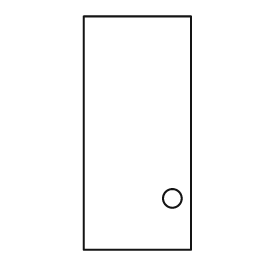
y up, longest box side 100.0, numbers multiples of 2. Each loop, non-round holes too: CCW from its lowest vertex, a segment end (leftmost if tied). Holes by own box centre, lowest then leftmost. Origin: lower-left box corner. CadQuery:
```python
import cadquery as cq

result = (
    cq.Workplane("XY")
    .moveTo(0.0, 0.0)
    .lineTo(46.0, 0.0)
    .lineTo(46.0, 100.0)
    .lineTo(0.0, 100.0)
    .close()
    .moveTo(38.0, 22.0)
    .circle(4.0)
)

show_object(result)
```